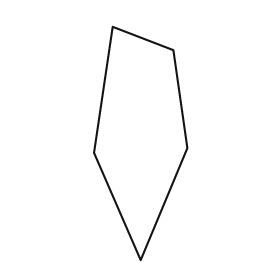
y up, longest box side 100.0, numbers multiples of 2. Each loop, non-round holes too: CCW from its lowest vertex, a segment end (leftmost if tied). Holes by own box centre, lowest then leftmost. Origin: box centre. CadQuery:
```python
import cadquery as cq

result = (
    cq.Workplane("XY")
    .moveTo(0.0, -50.0)
    .lineTo(20.0, -2.0)
    .lineTo(14.0, 40.0)
    .lineTo(-12.0, 50.0)
    .lineTo(-20.0, -4.0)
    .close()
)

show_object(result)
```